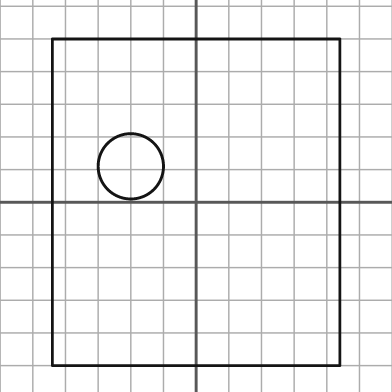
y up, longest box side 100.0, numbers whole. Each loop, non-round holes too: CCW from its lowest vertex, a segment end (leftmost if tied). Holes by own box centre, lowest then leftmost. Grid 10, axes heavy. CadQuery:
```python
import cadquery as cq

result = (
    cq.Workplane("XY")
    .moveTo(-44.0, -50.0)
    .lineTo(44.0, -50.0)
    .lineTo(44.0, 50.0)
    .lineTo(-44.0, 50.0)
    .close()
    .moveTo(-20.0, 11.0)
    .circle(10.0)
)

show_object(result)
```